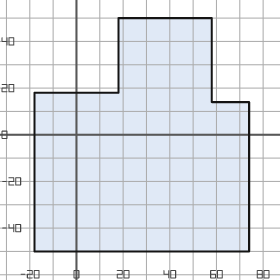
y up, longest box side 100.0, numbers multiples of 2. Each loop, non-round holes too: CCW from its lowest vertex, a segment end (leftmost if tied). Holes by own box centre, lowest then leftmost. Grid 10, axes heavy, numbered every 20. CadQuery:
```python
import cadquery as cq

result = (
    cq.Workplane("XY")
    .moveTo(-18.0, -50.0)
    .lineTo(74.0, -50.0)
    .lineTo(74.0, 14.0)
    .lineTo(58.0, 14.0)
    .lineTo(58.0, 50.0)
    .lineTo(18.0, 50.0)
    .lineTo(18.0, 18.0)
    .lineTo(-18.0, 18.0)
    .close()
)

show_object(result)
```